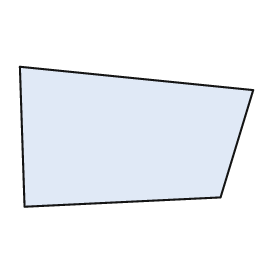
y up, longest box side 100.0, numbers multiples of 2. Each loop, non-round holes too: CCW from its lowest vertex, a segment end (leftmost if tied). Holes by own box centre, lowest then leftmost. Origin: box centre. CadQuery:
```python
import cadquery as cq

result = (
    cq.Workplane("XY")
    .moveTo(-48.0, -30.0)
    .lineTo(36.0, -26.0)
    .lineTo(50.0, 20.0)
    .lineTo(-50.0, 30.0)
    .close()
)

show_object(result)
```